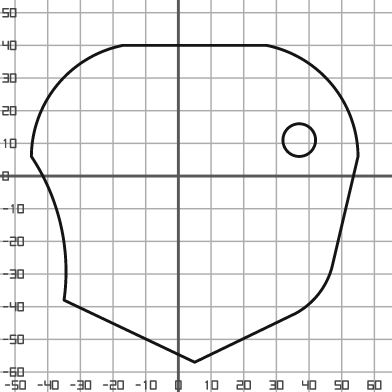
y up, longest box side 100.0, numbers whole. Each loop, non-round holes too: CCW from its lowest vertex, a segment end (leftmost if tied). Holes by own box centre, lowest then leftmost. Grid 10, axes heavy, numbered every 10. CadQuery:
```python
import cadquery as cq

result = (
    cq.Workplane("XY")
    .moveTo(5.0, -57.0)
    .lineTo(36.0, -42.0)
    .threePointArc((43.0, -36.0), (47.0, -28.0))
    .lineTo(55.0, 6.0)
    .threePointArc((47.0, 28.0), (27.0, 40.0))
    .lineTo(-17.0, 40.0)
    .threePointArc((-37.0, 28.0), (-45.0, 6.0))
    .threePointArc((-36.0, -15.0), (-35.0, -38.0))
    .close()
    .moveTo(37.0, 11.0)
    .circle(5.0)
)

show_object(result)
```